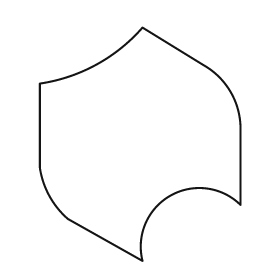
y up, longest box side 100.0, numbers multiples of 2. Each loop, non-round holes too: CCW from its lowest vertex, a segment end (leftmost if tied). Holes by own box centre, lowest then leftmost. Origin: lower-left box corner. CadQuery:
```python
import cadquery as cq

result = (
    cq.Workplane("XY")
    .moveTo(44.0, 0.0)
    .threePointArc((56.0, 28.0), (86.0, 24.0))
    .lineTo(86.0, 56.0)
    .threePointArc((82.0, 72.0), (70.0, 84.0))
    .lineTo(44.0, 100.0)
    .threePointArc((24.0, 84.0), (0.0, 76.0))
    .lineTo(0.0, 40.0)
    .threePointArc((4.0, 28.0), (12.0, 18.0))
    .close()
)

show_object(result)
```